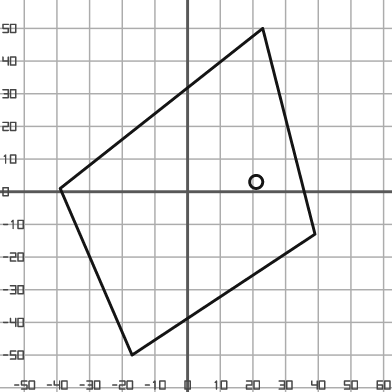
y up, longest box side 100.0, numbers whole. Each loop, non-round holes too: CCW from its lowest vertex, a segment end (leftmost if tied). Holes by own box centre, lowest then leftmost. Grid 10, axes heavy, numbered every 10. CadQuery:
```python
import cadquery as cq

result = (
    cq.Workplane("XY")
    .moveTo(-17.0, -50.0)
    .lineTo(39.0, -13.0)
    .lineTo(23.0, 50.0)
    .lineTo(-39.0, 1.0)
    .close()
    .moveTo(21.0, 3.0)
    .circle(2.0)
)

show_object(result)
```